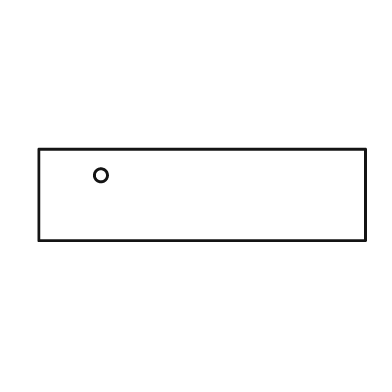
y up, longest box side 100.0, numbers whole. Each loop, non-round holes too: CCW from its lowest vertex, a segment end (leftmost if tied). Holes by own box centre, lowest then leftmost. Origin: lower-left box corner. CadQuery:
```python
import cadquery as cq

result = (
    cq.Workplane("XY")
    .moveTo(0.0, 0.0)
    .lineTo(100.0, 0.0)
    .lineTo(100.0, 28.0)
    .lineTo(0.0, 28.0)
    .close()
    .moveTo(19.0, 20.0)
    .circle(2.0)
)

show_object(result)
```